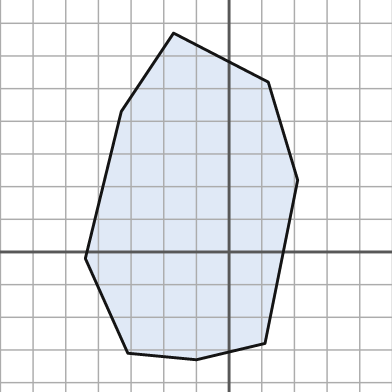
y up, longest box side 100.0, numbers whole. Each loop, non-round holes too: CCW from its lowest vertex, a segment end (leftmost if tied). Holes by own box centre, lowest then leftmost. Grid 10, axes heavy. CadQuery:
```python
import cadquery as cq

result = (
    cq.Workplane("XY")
    .moveTo(-10.0, -33.0)
    .lineTo(11.0, -28.0)
    .lineTo(21.0, 22.0)
    .lineTo(12.0, 52.0)
    .lineTo(-17.0, 67.0)
    .lineTo(-33.0, 43.0)
    .lineTo(-44.0, -2.0)
    .lineTo(-31.0, -31.0)
    .close()
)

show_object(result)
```